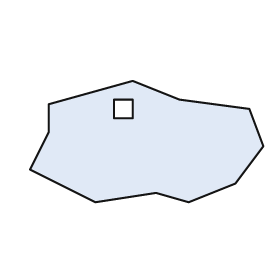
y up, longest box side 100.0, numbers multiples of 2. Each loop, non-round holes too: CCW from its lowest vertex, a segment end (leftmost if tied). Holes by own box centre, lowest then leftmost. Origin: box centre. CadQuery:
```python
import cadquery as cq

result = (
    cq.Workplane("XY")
    .moveTo(-22.0, -26.0)
    .lineTo(4.0, -22.0)
    .lineTo(18.0, -26.0)
    .lineTo(38.0, -18.0)
    .lineTo(50.0, -2.0)
    .lineTo(44.0, 14.0)
    .lineTo(14.0, 18.0)
    .lineTo(-6.0, 26.0)
    .lineTo(-42.0, 16.0)
    .lineTo(-42.0, 4.0)
    .lineTo(-50.0, -12.0)
    .close()
    .moveTo(-14.0, 10.0)
    .lineTo(-6.0, 10.0)
    .lineTo(-6.0, 18.0)
    .lineTo(-14.0, 18.0)
    .close()
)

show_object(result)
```